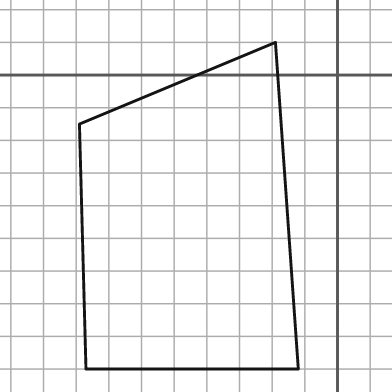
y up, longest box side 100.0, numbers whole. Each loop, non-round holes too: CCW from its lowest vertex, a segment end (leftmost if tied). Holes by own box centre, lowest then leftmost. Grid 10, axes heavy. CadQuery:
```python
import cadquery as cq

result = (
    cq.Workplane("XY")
    .moveTo(-77.0, -90.0)
    .lineTo(-12.0, -90.0)
    .lineTo(-19.0, 10.0)
    .lineTo(-79.0, -15.0)
    .close()
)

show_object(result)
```